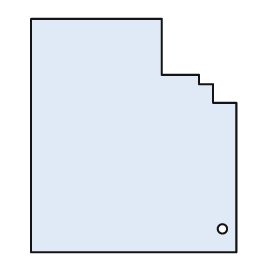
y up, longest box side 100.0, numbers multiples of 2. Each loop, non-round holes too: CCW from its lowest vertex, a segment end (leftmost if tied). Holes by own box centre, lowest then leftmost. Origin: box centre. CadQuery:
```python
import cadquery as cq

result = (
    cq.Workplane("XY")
    .moveTo(-44.0, -50.0)
    .lineTo(44.0, -50.0)
    .lineTo(44.0, 14.0)
    .lineTo(34.0, 14.0)
    .lineTo(34.0, 22.0)
    .lineTo(28.0, 22.0)
    .lineTo(28.0, 26.0)
    .lineTo(12.0, 26.0)
    .lineTo(12.0, 50.0)
    .lineTo(-44.0, 50.0)
    .close()
    .moveTo(38.0, -40.0)
    .circle(2.0)
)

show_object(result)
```